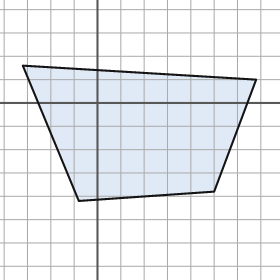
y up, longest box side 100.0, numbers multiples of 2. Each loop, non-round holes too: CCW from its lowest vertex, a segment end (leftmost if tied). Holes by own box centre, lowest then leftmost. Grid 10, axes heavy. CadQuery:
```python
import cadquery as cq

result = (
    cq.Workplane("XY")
    .moveTo(-8.0, -42.0)
    .lineTo(50.0, -38.0)
    .lineTo(68.0, 10.0)
    .lineTo(-32.0, 16.0)
    .close()
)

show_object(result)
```